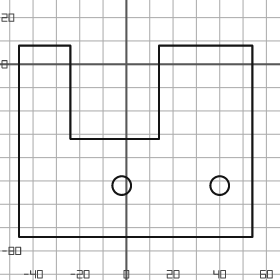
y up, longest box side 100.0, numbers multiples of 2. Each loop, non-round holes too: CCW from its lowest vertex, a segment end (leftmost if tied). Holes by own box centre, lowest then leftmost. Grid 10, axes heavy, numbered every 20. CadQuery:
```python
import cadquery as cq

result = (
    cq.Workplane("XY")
    .moveTo(-46.0, -74.0)
    .lineTo(54.0, -74.0)
    .lineTo(54.0, 8.0)
    .lineTo(14.0, 8.0)
    .lineTo(14.0, -32.0)
    .lineTo(-24.0, -32.0)
    .lineTo(-24.0, 8.0)
    .lineTo(-46.0, 8.0)
    .close()
    .moveTo(-2.0, -52.0)
    .circle(4.0)
    .moveTo(40.0, -52.0)
    .circle(4.0)
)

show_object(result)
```